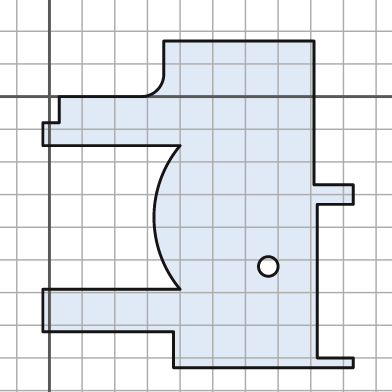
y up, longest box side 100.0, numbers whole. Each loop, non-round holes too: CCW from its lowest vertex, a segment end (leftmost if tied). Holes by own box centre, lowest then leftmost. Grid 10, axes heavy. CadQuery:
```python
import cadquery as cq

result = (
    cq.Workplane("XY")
    .moveTo(38.0, -83.0)
    .lineTo(93.0, -83.0)
    .lineTo(93.0, -80.0)
    .lineTo(82.0, -80.0)
    .lineTo(82.0, -33.0)
    .lineTo(93.0, -33.0)
    .lineTo(93.0, -27.0)
    .lineTo(81.0, -27.0)
    .lineTo(81.0, 17.0)
    .lineTo(35.0, 17.0)
    .lineTo(35.0, 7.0)
    .threePointArc((33.0, 2.0), (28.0, 0.0))
    .lineTo(3.0, 0.0)
    .lineTo(3.0, -8.0)
    .lineTo(-2.0, -8.0)
    .lineTo(-2.0, -15.0)
    .lineTo(40.0, -15.0)
    .threePointArc((32.0, -37.0), (40.0, -59.0))
    .lineTo(-2.0, -59.0)
    .lineTo(-2.0, -72.0)
    .lineTo(38.0, -72.0)
    .close()
    .moveTo(67.0, -52.0)
    .circle(3.0)
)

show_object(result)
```